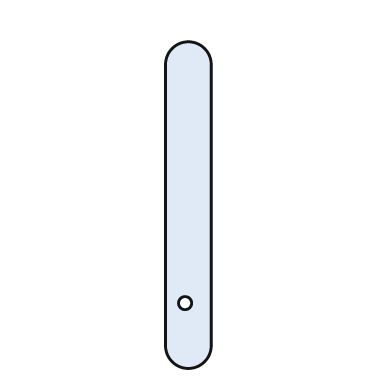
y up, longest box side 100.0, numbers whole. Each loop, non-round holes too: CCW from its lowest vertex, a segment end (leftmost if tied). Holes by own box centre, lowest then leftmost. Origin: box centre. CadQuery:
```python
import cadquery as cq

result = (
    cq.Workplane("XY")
    .moveTo(-7.0, -43.0)
    .threePointArc((0.0, -50.0), (7.0, -43.0))
    .lineTo(7.0, 43.0)
    .threePointArc((0.0, 50.0), (-7.0, 43.0))
    .close()
    .moveTo(-1.0, -30.0)
    .circle(2.0)
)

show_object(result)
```